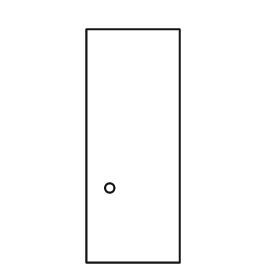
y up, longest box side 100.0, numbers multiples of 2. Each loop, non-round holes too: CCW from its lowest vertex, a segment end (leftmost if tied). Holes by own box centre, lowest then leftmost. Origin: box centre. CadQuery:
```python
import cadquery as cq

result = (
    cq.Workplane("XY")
    .moveTo(-20.0, -50.0)
    .lineTo(20.0, -50.0)
    .lineTo(20.0, 50.0)
    .lineTo(-20.0, 50.0)
    .close()
    .moveTo(-10.0, -18.0)
    .circle(2.0)
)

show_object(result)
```